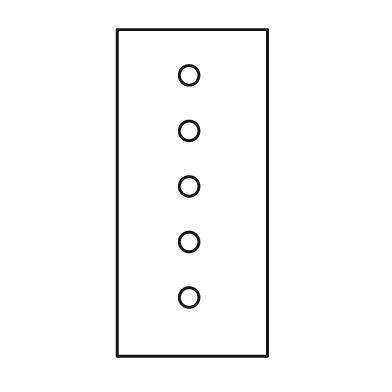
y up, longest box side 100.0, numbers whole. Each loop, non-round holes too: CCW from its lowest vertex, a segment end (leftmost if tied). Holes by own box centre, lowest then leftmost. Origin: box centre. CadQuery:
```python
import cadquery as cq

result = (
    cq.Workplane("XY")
    .moveTo(-23.0, -50.0)
    .lineTo(23.0, -50.0)
    .lineTo(23.0, 50.0)
    .lineTo(-23.0, 50.0)
    .close()
    .moveTo(-1.0, -32.0)
    .circle(3.0)
    .moveTo(-1.0, -15.0)
    .circle(3.0)
    .moveTo(-1.0, 2.0)
    .circle(3.0)
    .moveTo(-1.0, 19.0)
    .circle(3.0)
    .moveTo(-1.0, 36.0)
    .circle(3.0)
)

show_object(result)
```